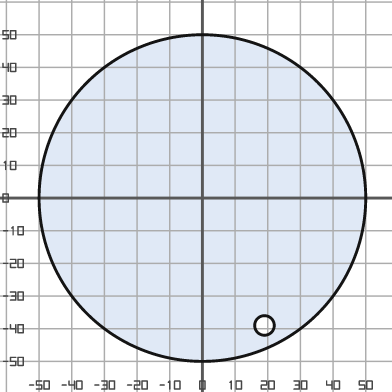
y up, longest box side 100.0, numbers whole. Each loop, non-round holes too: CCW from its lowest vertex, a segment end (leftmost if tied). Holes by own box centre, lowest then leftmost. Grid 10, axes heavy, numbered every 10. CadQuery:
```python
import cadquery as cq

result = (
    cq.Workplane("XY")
    .moveTo(0.0, 0.0)
    .circle(50.0)
    .moveTo(19.0, -39.0)
    .circle(3.0)
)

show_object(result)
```